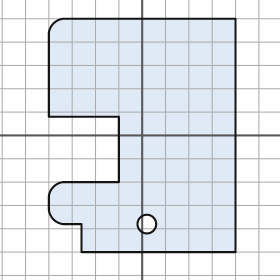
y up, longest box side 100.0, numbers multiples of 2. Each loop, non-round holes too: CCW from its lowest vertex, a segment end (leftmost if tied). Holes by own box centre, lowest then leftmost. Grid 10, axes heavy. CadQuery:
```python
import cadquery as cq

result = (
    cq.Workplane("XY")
    .moveTo(-26.0, -50.0)
    .lineTo(40.0, -50.0)
    .lineTo(40.0, 50.0)
    .lineTo(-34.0, 50.0)
    .threePointArc((-38.0, 48.0), (-40.0, 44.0))
    .lineTo(-40.0, 8.0)
    .lineTo(-10.0, 8.0)
    .lineTo(-10.0, -20.0)
    .lineTo(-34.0, -20.0)
    .threePointArc((-38.0, -22.0), (-40.0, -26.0))
    .lineTo(-40.0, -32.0)
    .threePointArc((-38.0, -36.0), (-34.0, -38.0))
    .lineTo(-26.0, -38.0)
    .close()
    .moveTo(2.0, -38.0)
    .circle(4.0)
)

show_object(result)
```